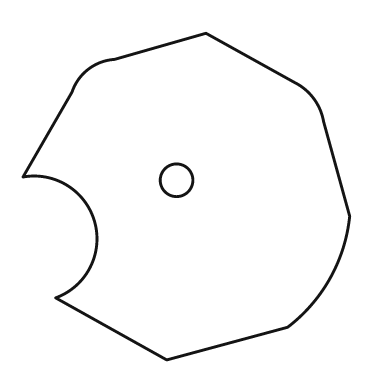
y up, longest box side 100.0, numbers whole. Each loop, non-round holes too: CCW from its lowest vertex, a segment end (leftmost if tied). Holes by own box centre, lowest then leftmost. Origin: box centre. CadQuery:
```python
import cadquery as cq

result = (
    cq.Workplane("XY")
    .moveTo(-6.0, -50.0)
    .lineTo(31.0, -40.0)
    .threePointArc((44.0, -25.0), (50.0, -6.0))
    .lineTo(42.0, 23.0)
    .threePointArc((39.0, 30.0), (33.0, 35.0))
    .lineTo(6.0, 50.0)
    .lineTo(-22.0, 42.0)
    .threePointArc((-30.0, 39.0), (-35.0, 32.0))
    .lineTo(-50.0, 6.0)
    .threePointArc((-28.0, -8.0), (-40.0, -31.0))
    .close()
    .moveTo(-3.0, 5.0)
    .circle(5.0)
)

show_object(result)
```